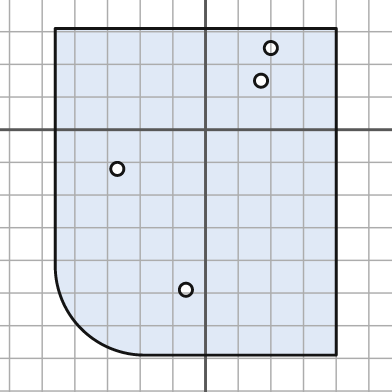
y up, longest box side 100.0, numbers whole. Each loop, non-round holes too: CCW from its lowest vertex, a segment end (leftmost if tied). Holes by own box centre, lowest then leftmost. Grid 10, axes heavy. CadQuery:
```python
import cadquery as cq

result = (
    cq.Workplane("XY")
    .moveTo(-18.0, -69.0)
    .lineTo(40.0, -69.0)
    .lineTo(40.0, 31.0)
    .lineTo(-46.0, 31.0)
    .lineTo(-46.0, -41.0)
    .threePointArc((-38.0, -61.0), (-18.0, -69.0))
    .close()
    .moveTo(-6.0, -49.0)
    .circle(2.0)
    .moveTo(-27.0, -12.0)
    .circle(2.0)
    .moveTo(17.0, 15.0)
    .circle(2.0)
    .moveTo(20.0, 25.0)
    .circle(2.0)
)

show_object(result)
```